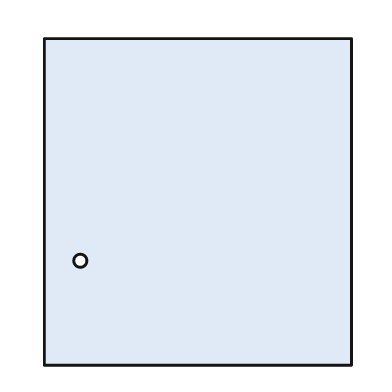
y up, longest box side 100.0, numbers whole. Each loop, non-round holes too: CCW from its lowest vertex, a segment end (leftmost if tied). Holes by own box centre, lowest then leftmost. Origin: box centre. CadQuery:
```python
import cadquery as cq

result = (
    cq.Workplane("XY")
    .moveTo(-47.0, -50.0)
    .lineTo(47.0, -50.0)
    .lineTo(47.0, 50.0)
    .lineTo(-47.0, 50.0)
    .close()
    .moveTo(-36.0, -18.0)
    .circle(2.0)
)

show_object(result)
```